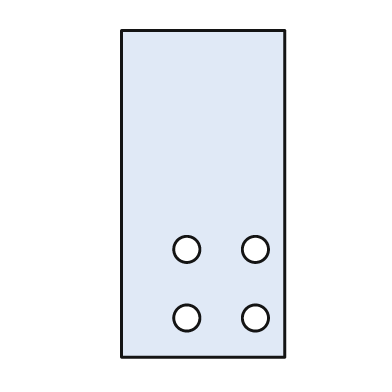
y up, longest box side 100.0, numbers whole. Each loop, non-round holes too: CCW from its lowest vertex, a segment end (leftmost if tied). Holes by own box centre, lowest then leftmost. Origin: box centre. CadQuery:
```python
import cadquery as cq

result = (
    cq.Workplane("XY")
    .moveTo(-25.0, -50.0)
    .lineTo(25.0, -50.0)
    .lineTo(25.0, 50.0)
    .lineTo(-25.0, 50.0)
    .close()
    .moveTo(-5.0, -38.0)
    .circle(4.0)
    .moveTo(16.0, -38.0)
    .circle(4.0)
    .moveTo(-5.0, -17.0)
    .circle(4.0)
    .moveTo(16.0, -17.0)
    .circle(4.0)
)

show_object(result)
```